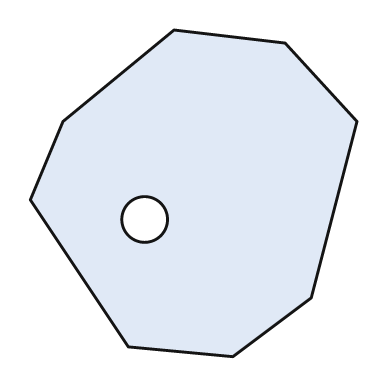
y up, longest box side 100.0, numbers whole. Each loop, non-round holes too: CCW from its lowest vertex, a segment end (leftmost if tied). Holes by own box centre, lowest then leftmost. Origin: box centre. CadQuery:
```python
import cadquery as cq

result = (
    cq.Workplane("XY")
    .moveTo(12.0, -50.0)
    .lineTo(36.0, -32.0)
    .lineTo(50.0, 22.0)
    .lineTo(28.0, 46.0)
    .lineTo(-6.0, 50.0)
    .lineTo(-40.0, 22.0)
    .lineTo(-50.0, -2.0)
    .lineTo(-20.0, -47.0)
    .close()
    .moveTo(-15.0, -8.0)
    .circle(7.0)
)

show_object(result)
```